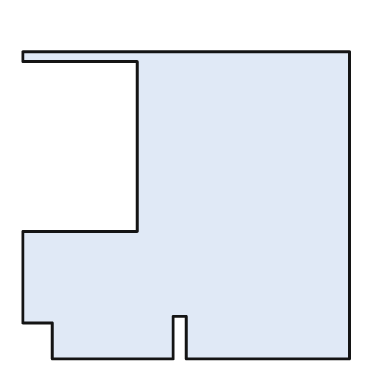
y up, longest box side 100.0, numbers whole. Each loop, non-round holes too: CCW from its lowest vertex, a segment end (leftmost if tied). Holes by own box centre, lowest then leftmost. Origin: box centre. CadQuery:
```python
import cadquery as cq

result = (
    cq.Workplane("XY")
    .moveTo(-41.0, -47.0)
    .lineTo(-4.0, -47.0)
    .lineTo(-4.0, -34.0)
    .lineTo(0.0, -34.0)
    .lineTo(0.0, -47.0)
    .lineTo(50.0, -47.0)
    .lineTo(50.0, 47.0)
    .lineTo(-50.0, 47.0)
    .lineTo(-50.0, 44.0)
    .lineTo(-15.0, 44.0)
    .lineTo(-15.0, -8.0)
    .lineTo(-50.0, -8.0)
    .lineTo(-50.0, -36.0)
    .lineTo(-41.0, -36.0)
    .close()
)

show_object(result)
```